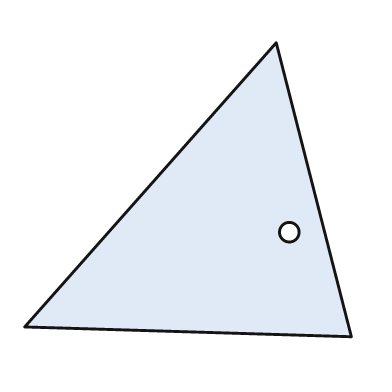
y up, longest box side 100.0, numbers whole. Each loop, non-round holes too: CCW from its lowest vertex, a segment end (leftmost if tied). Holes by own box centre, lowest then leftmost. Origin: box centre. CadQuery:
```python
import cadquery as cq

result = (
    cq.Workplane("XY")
    .moveTo(50.0, -45.0)
    .lineTo(27.0, 45.0)
    .lineTo(-50.0, -42.0)
    .close()
    .moveTo(31.0, -13.0)
    .circle(3.0)
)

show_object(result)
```